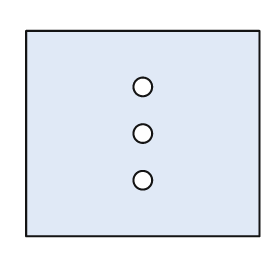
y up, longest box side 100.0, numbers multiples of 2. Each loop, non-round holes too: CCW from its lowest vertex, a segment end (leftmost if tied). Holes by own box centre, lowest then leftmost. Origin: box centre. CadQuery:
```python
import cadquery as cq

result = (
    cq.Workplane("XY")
    .moveTo(-50.0, -44.0)
    .lineTo(50.0, -44.0)
    .lineTo(50.0, 44.0)
    .lineTo(-50.0, 44.0)
    .close()
    .moveTo(0.0, -20.0)
    .circle(4.0)
    .moveTo(0.0, 0.0)
    .circle(4.0)
    .moveTo(0.0, 20.0)
    .circle(4.0)
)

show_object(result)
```